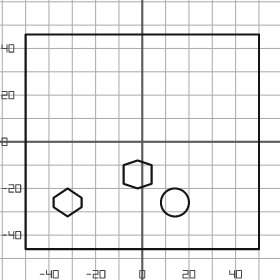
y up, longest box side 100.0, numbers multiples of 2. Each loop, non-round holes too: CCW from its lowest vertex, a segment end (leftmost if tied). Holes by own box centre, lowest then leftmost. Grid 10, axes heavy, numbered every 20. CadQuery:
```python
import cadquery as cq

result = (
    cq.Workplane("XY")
    .moveTo(-50.0, -46.0)
    .lineTo(50.0, -46.0)
    .lineTo(50.0, 46.0)
    .lineTo(-50.0, 46.0)
    .close()
    .moveTo(-32.0, -32.0)
    .lineTo(-26.0, -28.0)
    .lineTo(-26.0, -24.0)
    .lineTo(-32.0, -20.0)
    .lineTo(-38.0, -24.0)
    .lineTo(-38.0, -28.0)
    .close()
    .moveTo(14.0, -26.0)
    .circle(6.0)
    .moveTo(-2.0, -20.0)
    .lineTo(4.0, -18.0)
    .lineTo(4.0, -10.0)
    .lineTo(-2.0, -8.0)
    .lineTo(-8.0, -10.0)
    .lineTo(-8.0, -18.0)
    .close()
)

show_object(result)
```